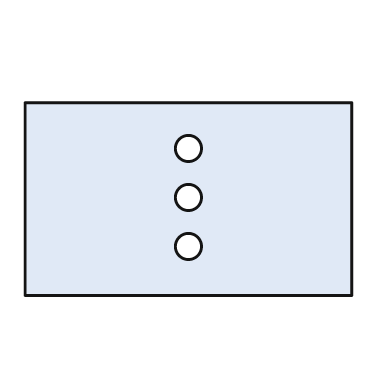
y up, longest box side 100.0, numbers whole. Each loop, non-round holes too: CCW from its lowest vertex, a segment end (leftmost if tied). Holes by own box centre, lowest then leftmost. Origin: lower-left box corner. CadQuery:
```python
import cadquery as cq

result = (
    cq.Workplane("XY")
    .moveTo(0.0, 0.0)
    .lineTo(100.0, 0.0)
    .lineTo(100.0, 59.0)
    .lineTo(0.0, 59.0)
    .close()
    .moveTo(50.0, 15.0)
    .circle(4.0)
    .moveTo(50.0, 30.0)
    .circle(4.0)
    .moveTo(50.0, 45.0)
    .circle(4.0)
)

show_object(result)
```